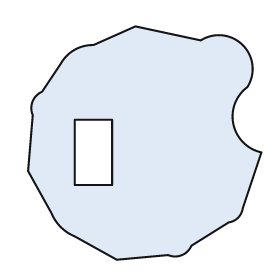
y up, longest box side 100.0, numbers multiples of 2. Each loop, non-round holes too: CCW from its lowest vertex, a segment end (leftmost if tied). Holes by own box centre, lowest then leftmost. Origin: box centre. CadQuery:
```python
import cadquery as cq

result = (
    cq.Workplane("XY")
    .moveTo(-12.0, -50.0)
    .lineTo(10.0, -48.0)
    .threePointArc((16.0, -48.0), (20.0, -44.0))
    .lineTo(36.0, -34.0)
    .threePointArc((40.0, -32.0), (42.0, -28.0))
    .lineTo(50.0, -4.0)
    .threePointArc((38.0, 8.0), (44.0, 24.0))
    .threePointArc((42.0, 42.0), (24.0, 44.0))
    .lineTo(-4.0, 50.0)
    .lineTo(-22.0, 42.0)
    .threePointArc((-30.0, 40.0), (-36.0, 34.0))
    .lineTo(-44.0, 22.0)
    .threePointArc((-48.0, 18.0), (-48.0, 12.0))
    .lineTo(-50.0, -12.0)
    .lineTo(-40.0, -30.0)
    .threePointArc((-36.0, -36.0), (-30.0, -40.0))
    .close()
    .moveTo(-30.0, -18.0)
    .lineTo(-14.0, -18.0)
    .lineTo(-14.0, 10.0)
    .lineTo(-30.0, 10.0)
    .close()
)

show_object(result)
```